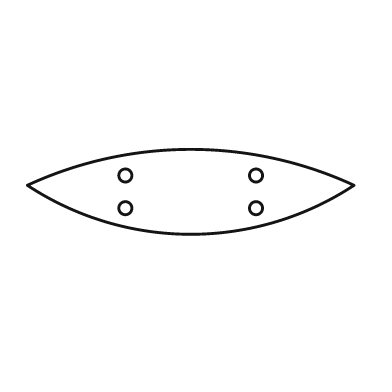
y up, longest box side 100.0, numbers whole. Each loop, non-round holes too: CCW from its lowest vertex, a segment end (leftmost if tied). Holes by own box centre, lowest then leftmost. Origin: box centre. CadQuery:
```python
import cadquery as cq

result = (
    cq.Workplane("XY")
    .moveTo(-50.0, 2.0)
    .threePointArc((0.0, -13.0), (50.0, 2.0))
    .threePointArc((0.0, 13.0), (-50.0, 2.0))
    .close()
    .moveTo(-20.0, -5.0)
    .circle(2.0)
    .moveTo(20.0, -5.0)
    .circle(2.0)
    .moveTo(-20.0, 5.0)
    .circle(2.0)
    .moveTo(20.0, 5.0)
    .circle(2.0)
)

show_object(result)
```